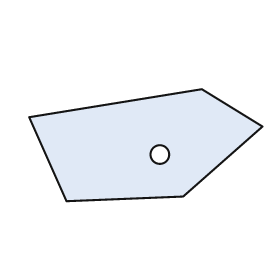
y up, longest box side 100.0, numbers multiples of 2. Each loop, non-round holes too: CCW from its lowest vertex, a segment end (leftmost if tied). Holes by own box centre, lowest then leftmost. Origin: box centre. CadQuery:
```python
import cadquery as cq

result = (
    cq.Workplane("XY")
    .moveTo(-34.0, -24.0)
    .lineTo(16.0, -22.0)
    .lineTo(50.0, 8.0)
    .lineTo(24.0, 24.0)
    .lineTo(-50.0, 12.0)
    .close()
    .moveTo(6.0, -4.0)
    .circle(4.0)
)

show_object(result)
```